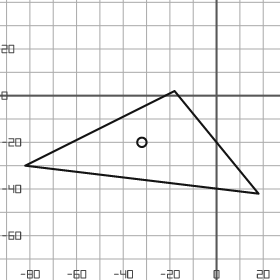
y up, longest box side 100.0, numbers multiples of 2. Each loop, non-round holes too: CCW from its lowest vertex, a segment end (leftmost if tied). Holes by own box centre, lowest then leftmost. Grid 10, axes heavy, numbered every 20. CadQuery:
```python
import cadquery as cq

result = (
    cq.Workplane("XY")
    .moveTo(18.0, -42.0)
    .lineTo(-18.0, 2.0)
    .lineTo(-82.0, -30.0)
    .close()
    .moveTo(-32.0, -20.0)
    .circle(2.0)
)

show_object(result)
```